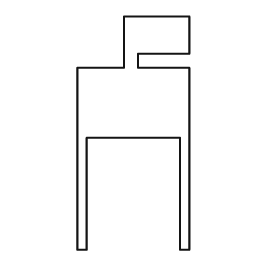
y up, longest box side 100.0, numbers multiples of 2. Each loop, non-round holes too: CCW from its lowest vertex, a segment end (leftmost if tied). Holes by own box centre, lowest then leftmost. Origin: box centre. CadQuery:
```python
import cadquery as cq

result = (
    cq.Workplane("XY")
    .moveTo(-24.0, -50.0)
    .lineTo(-20.0, -50.0)
    .lineTo(-20.0, -2.0)
    .lineTo(20.0, -2.0)
    .lineTo(20.0, -50.0)
    .lineTo(24.0, -50.0)
    .lineTo(24.0, 28.0)
    .lineTo(2.0, 28.0)
    .lineTo(2.0, 34.0)
    .lineTo(24.0, 34.0)
    .lineTo(24.0, 50.0)
    .lineTo(-4.0, 50.0)
    .lineTo(-4.0, 28.0)
    .lineTo(-24.0, 28.0)
    .close()
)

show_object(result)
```